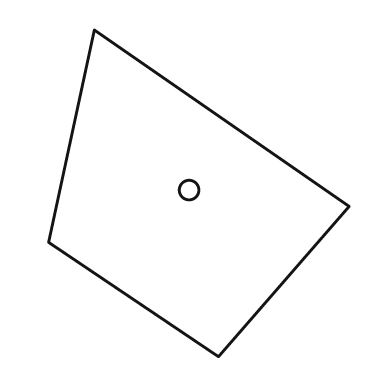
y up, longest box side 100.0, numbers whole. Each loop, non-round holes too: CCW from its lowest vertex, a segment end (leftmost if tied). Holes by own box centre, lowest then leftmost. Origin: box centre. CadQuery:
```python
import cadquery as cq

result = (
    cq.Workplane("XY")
    .moveTo(6.0, -50.0)
    .lineTo(46.0, -4.0)
    .lineTo(-32.0, 50.0)
    .lineTo(-46.0, -15.0)
    .close()
    .moveTo(-3.0, 1.0)
    .circle(3.0)
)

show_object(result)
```